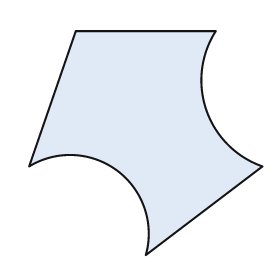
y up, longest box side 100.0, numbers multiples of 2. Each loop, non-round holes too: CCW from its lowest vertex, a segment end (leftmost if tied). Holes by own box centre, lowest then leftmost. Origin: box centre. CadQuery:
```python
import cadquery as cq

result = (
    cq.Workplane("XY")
    .moveTo(0.0, -48.0)
    .lineTo(50.0, -10.0)
    .threePointArc((26.0, 14.0), (30.0, 48.0))
    .lineTo(-30.0, 48.0)
    .lineTo(-50.0, -10.0)
    .threePointArc((-12.0, -12.0), (0.0, -48.0))
    .close()
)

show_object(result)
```